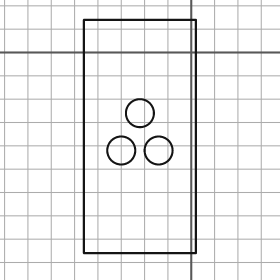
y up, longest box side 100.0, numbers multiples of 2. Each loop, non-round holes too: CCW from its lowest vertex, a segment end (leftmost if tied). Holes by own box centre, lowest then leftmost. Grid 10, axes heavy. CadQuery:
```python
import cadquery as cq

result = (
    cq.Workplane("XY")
    .moveTo(-46.0, -86.0)
    .lineTo(2.0, -86.0)
    .lineTo(2.0, 14.0)
    .lineTo(-46.0, 14.0)
    .close()
    .moveTo(-30.0, -42.0)
    .circle(6.0)
    .moveTo(-14.0, -42.0)
    .circle(6.0)
    .moveTo(-22.0, -26.0)
    .circle(6.0)
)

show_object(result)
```